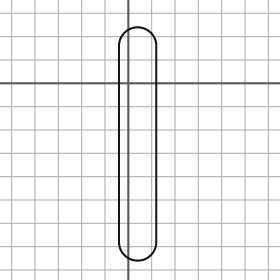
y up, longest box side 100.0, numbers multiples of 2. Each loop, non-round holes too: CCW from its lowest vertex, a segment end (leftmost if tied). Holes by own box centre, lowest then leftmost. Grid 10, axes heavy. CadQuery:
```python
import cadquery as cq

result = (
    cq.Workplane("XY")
    .moveTo(-4.0, -68.0)
    .threePointArc((4.0, -76.0), (12.0, -68.0))
    .lineTo(12.0, 16.0)
    .threePointArc((4.0, 24.0), (-4.0, 16.0))
    .close()
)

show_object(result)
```